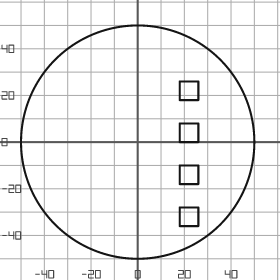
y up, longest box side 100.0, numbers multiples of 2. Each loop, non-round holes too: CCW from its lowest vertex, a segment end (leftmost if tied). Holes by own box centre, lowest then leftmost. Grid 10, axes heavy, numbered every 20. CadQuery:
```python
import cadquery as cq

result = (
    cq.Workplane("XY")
    .moveTo(0.0, 0.0)
    .circle(50.0)
    .moveTo(18.0, -36.0)
    .lineTo(26.0, -36.0)
    .lineTo(26.0, -28.0)
    .lineTo(18.0, -28.0)
    .close()
    .moveTo(18.0, -18.0)
    .lineTo(26.0, -18.0)
    .lineTo(26.0, -10.0)
    .lineTo(18.0, -10.0)
    .close()
    .moveTo(18.0, 0.0)
    .lineTo(26.0, 0.0)
    .lineTo(26.0, 8.0)
    .lineTo(18.0, 8.0)
    .close()
    .moveTo(18.0, 18.0)
    .lineTo(26.0, 18.0)
    .lineTo(26.0, 26.0)
    .lineTo(18.0, 26.0)
    .close()
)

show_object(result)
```